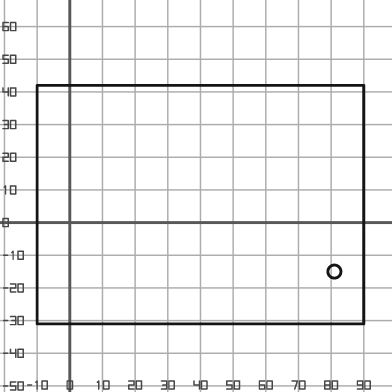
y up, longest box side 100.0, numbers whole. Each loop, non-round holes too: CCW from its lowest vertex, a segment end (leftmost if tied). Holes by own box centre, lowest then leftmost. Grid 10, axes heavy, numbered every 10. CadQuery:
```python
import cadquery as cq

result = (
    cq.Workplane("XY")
    .moveTo(-10.0, -31.0)
    .lineTo(90.0, -31.0)
    .lineTo(90.0, 42.0)
    .lineTo(-10.0, 42.0)
    .close()
    .moveTo(81.0, -15.0)
    .circle(2.0)
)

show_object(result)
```